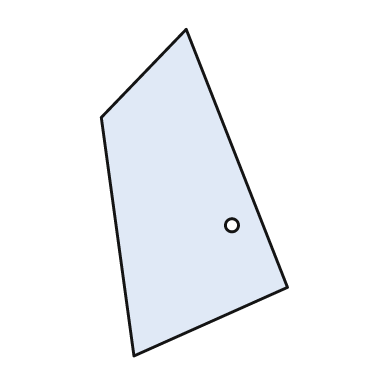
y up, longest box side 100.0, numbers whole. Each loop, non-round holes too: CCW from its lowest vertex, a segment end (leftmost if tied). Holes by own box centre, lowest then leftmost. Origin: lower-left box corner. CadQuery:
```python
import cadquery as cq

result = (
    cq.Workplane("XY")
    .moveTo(10.0, 0.0)
    .lineTo(57.0, 21.0)
    .lineTo(26.0, 100.0)
    .lineTo(0.0, 73.0)
    .close()
    .moveTo(40.0, 40.0)
    .circle(2.0)
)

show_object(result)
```